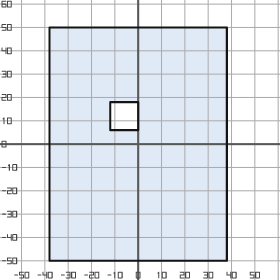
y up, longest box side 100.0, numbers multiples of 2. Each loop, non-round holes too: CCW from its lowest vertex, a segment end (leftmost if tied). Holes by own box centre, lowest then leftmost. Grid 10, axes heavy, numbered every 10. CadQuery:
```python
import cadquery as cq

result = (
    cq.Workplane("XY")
    .moveTo(-38.0, -50.0)
    .lineTo(38.0, -50.0)
    .lineTo(38.0, 50.0)
    .lineTo(-38.0, 50.0)
    .close()
    .moveTo(-12.0, 6.0)
    .lineTo(0.0, 6.0)
    .lineTo(0.0, 18.0)
    .lineTo(-12.0, 18.0)
    .close()
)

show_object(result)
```